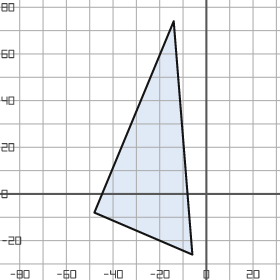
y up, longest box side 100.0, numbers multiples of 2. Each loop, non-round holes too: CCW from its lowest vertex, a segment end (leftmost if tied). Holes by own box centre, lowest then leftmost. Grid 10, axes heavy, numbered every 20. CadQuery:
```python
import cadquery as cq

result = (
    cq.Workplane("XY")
    .moveTo(-6.0, -26.0)
    .lineTo(-14.0, 74.0)
    .lineTo(-48.0, -8.0)
    .close()
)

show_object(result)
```